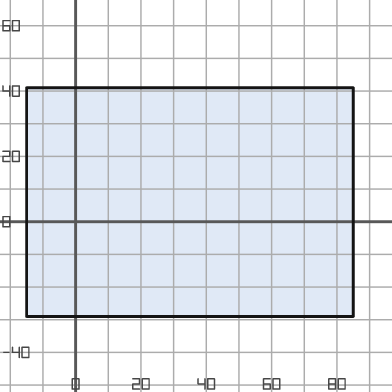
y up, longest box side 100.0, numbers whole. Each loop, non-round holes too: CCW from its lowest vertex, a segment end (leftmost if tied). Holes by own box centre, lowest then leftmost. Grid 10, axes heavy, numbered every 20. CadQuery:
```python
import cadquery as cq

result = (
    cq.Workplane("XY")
    .moveTo(-15.0, -29.0)
    .lineTo(85.0, -29.0)
    .lineTo(85.0, 41.0)
    .lineTo(-15.0, 41.0)
    .close()
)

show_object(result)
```